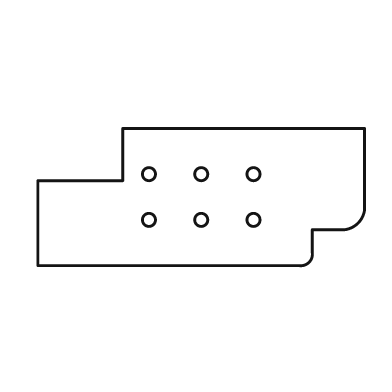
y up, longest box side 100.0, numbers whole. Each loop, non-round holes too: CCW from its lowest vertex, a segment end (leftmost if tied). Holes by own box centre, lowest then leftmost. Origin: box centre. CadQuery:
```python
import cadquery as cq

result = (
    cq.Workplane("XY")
    .moveTo(-50.0, -21.0)
    .lineTo(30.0, -21.0)
    .threePointArc((33.0, -20.0), (34.0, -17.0))
    .lineTo(34.0, -10.0)
    .lineTo(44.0, -10.0)
    .threePointArc((48.0, -8.0), (50.0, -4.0))
    .lineTo(50.0, 21.0)
    .lineTo(-24.0, 21.0)
    .lineTo(-24.0, 5.0)
    .lineTo(-50.0, 5.0)
    .close()
    .moveTo(-16.0, -7.0)
    .circle(2.0)
    .moveTo(0.0, -7.0)
    .circle(2.0)
    .moveTo(16.0, -7.0)
    .circle(2.0)
    .moveTo(-16.0, 7.0)
    .circle(2.0)
    .moveTo(0.0, 7.0)
    .circle(2.0)
    .moveTo(16.0, 7.0)
    .circle(2.0)
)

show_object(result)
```